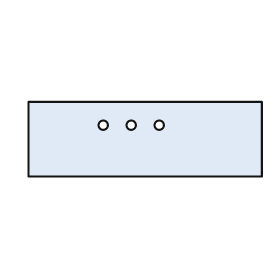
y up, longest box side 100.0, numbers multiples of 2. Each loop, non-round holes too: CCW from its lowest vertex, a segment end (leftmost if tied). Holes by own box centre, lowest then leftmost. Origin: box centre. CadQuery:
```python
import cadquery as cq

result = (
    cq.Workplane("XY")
    .moveTo(-50.0, -16.0)
    .lineTo(50.0, -16.0)
    .lineTo(50.0, 16.0)
    .lineTo(-50.0, 16.0)
    .close()
    .moveTo(-18.0, 6.0)
    .circle(2.0)
    .moveTo(-6.0, 6.0)
    .circle(2.0)
    .moveTo(6.0, 6.0)
    .circle(2.0)
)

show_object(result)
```